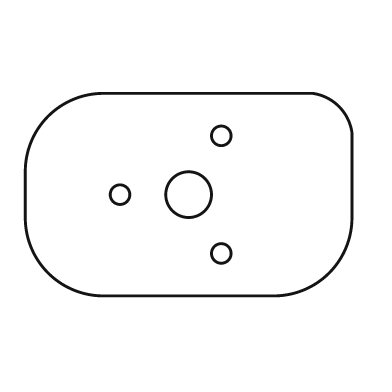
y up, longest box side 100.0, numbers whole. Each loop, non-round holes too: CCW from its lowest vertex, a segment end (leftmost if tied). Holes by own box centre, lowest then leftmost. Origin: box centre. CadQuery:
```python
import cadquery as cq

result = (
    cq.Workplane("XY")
    .moveTo(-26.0, -31.0)
    .lineTo(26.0, -31.0)
    .threePointArc((43.0, -24.0), (50.0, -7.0))
    .lineTo(50.0, 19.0)
    .threePointArc((46.0, 27.0), (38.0, 31.0))
    .lineTo(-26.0, 31.0)
    .threePointArc((-43.0, 24.0), (-50.0, 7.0))
    .lineTo(-50.0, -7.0)
    .threePointArc((-43.0, -24.0), (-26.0, -31.0))
    .close()
    .moveTo(10.0, -18.0)
    .circle(3.0)
    .moveTo(-21.0, 0.0)
    .circle(3.0)
    .moveTo(0.0, 0.0)
    .circle(7.0)
    .moveTo(10.0, 18.0)
    .circle(3.0)
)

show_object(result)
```